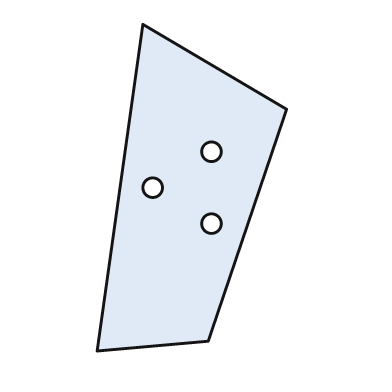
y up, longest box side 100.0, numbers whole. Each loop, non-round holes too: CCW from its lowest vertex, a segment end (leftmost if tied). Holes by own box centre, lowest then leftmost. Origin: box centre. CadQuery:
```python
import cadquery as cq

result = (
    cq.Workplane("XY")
    .moveTo(-29.0, -50.0)
    .lineTo(5.0, -47.0)
    .lineTo(29.0, 24.0)
    .lineTo(-15.0, 50.0)
    .close()
    .moveTo(6.0, -11.0)
    .circle(3.0)
    .moveTo(-12.0, 0.0)
    .circle(3.0)
    .moveTo(6.0, 11.0)
    .circle(3.0)
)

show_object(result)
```